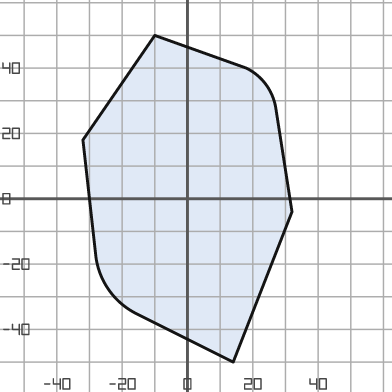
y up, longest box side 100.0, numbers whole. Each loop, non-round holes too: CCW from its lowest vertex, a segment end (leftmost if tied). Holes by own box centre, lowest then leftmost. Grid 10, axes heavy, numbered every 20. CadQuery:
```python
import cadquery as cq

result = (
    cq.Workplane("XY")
    .moveTo(14.0, -50.0)
    .lineTo(32.0, -4.0)
    .lineTo(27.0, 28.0)
    .threePointArc((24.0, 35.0), (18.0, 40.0))
    .lineTo(-10.0, 50.0)
    .lineTo(-32.0, 18.0)
    .lineTo(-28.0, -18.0)
    .threePointArc((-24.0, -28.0), (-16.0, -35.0))
    .close()
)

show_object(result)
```